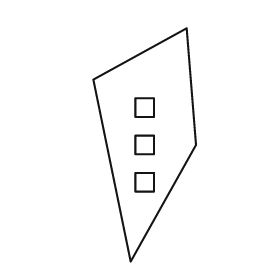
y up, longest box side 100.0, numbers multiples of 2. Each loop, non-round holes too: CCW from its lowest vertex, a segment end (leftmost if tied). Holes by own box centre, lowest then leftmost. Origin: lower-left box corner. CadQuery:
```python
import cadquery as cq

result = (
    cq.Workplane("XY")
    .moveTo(16.0, 0.0)
    .lineTo(44.0, 50.0)
    .lineTo(40.0, 100.0)
    .lineTo(0.0, 78.0)
    .close()
    .moveTo(18.0, 30.0)
    .lineTo(26.0, 30.0)
    .lineTo(26.0, 38.0)
    .lineTo(18.0, 38.0)
    .close()
    .moveTo(18.0, 46.0)
    .lineTo(26.0, 46.0)
    .lineTo(26.0, 54.0)
    .lineTo(18.0, 54.0)
    .close()
    .moveTo(18.0, 62.0)
    .lineTo(26.0, 62.0)
    .lineTo(26.0, 70.0)
    .lineTo(18.0, 70.0)
    .close()
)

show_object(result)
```